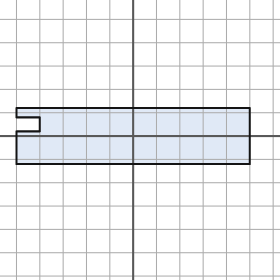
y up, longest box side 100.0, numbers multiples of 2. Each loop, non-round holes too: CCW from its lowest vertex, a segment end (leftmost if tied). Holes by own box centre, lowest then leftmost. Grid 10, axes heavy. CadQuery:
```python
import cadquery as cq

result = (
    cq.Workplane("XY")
    .moveTo(-50.0, -12.0)
    .lineTo(50.0, -12.0)
    .lineTo(50.0, 12.0)
    .lineTo(-50.0, 12.0)
    .lineTo(-50.0, 8.0)
    .lineTo(-40.0, 8.0)
    .lineTo(-40.0, 2.0)
    .lineTo(-50.0, 2.0)
    .close()
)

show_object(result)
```